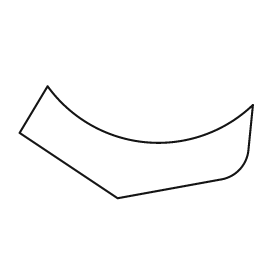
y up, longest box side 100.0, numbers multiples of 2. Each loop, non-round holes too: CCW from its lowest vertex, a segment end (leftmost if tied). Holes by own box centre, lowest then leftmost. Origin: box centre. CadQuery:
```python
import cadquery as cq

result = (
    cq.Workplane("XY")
    .moveTo(-8.0, -24.0)
    .lineTo(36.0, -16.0)
    .threePointArc((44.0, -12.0), (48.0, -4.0))
    .lineTo(50.0, 16.0)
    .threePointArc((4.0, 0.0), (-38.0, 24.0))
    .lineTo(-50.0, 4.0)
    .close()
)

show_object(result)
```